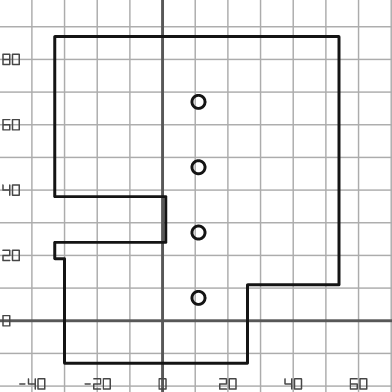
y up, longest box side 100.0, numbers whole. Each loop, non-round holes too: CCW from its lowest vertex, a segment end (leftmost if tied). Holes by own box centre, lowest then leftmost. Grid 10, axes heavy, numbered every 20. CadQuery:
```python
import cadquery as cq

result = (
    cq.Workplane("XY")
    .moveTo(-30.0, -13.0)
    .lineTo(26.0, -13.0)
    .lineTo(26.0, 11.0)
    .lineTo(54.0, 11.0)
    .lineTo(54.0, 87.0)
    .lineTo(-33.0, 87.0)
    .lineTo(-33.0, 38.0)
    .lineTo(1.0, 38.0)
    .lineTo(1.0, 24.0)
    .lineTo(-33.0, 24.0)
    .lineTo(-33.0, 19.0)
    .lineTo(-30.0, 19.0)
    .close()
    .moveTo(11.0, 7.0)
    .circle(2.0)
    .moveTo(11.0, 27.0)
    .circle(2.0)
    .moveTo(11.0, 47.0)
    .circle(2.0)
    .moveTo(11.0, 67.0)
    .circle(2.0)
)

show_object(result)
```